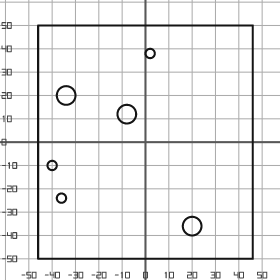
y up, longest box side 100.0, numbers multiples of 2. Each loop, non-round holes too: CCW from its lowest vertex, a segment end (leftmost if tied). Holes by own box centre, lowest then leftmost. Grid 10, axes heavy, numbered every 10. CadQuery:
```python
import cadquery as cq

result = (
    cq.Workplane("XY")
    .moveTo(-46.0, -50.0)
    .lineTo(46.0, -50.0)
    .lineTo(46.0, 50.0)
    .lineTo(-46.0, 50.0)
    .close()
    .moveTo(20.0, -36.0)
    .circle(4.0)
    .moveTo(-36.0, -24.0)
    .circle(2.0)
    .moveTo(-40.0, -10.0)
    .circle(2.0)
    .moveTo(-8.0, 12.0)
    .circle(4.0)
    .moveTo(-34.0, 20.0)
    .circle(4.0)
    .moveTo(2.0, 38.0)
    .circle(2.0)
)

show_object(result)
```